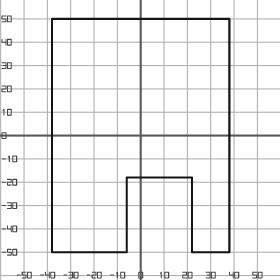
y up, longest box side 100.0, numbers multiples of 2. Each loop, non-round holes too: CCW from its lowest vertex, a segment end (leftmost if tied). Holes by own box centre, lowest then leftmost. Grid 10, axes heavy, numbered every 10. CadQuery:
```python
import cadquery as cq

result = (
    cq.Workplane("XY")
    .moveTo(-38.0, -50.0)
    .lineTo(-6.0, -50.0)
    .lineTo(-6.0, -18.0)
    .lineTo(22.0, -18.0)
    .lineTo(22.0, -50.0)
    .lineTo(38.0, -50.0)
    .lineTo(38.0, 50.0)
    .lineTo(-38.0, 50.0)
    .close()
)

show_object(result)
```